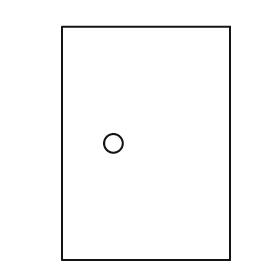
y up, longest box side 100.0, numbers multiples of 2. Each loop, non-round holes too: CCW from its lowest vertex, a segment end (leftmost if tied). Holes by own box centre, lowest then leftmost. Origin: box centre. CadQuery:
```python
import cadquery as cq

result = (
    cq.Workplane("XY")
    .moveTo(-36.0, -50.0)
    .lineTo(36.0, -50.0)
    .lineTo(36.0, 50.0)
    .lineTo(-36.0, 50.0)
    .close()
    .moveTo(-14.0, 0.0)
    .circle(4.0)
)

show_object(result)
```